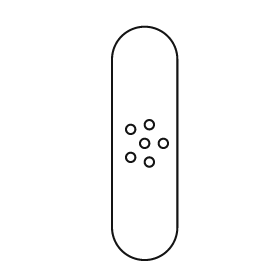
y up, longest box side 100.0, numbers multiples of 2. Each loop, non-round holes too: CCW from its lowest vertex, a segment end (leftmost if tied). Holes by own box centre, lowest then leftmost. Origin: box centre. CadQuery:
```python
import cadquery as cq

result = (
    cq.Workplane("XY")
    .moveTo(-14.0, -36.0)
    .threePointArc((0.0, -50.0), (14.0, -36.0))
    .lineTo(14.0, 36.0)
    .threePointArc((0.0, 50.0), (-14.0, 36.0))
    .close()
    .moveTo(2.0, -8.0)
    .circle(2.0)
    .moveTo(-6.0, -6.0)
    .circle(2.0)
    .moveTo(0.0, 0.0)
    .circle(2.0)
    .moveTo(8.0, 0.0)
    .circle(2.0)
    .moveTo(-6.0, 6.0)
    .circle(2.0)
    .moveTo(2.0, 8.0)
    .circle(2.0)
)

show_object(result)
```